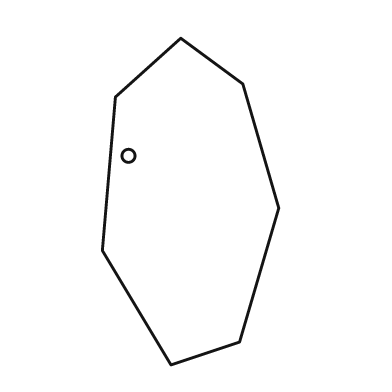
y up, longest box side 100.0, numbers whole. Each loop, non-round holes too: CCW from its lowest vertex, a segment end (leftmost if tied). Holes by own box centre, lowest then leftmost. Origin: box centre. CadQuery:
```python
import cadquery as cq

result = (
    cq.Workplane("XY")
    .moveTo(-6.0, -50.0)
    .lineTo(15.0, -43.0)
    .lineTo(27.0, -2.0)
    .lineTo(16.0, 36.0)
    .lineTo(-3.0, 50.0)
    .lineTo(-23.0, 32.0)
    .lineTo(-27.0, -15.0)
    .close()
    .moveTo(-19.0, 14.0)
    .circle(2.0)
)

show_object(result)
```